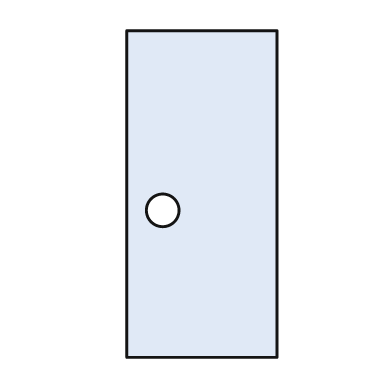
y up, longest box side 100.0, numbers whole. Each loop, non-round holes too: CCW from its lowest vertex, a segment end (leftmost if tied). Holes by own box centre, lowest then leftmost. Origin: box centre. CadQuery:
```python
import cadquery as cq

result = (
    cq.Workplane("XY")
    .moveTo(-23.0, -50.0)
    .lineTo(23.0, -50.0)
    .lineTo(23.0, 50.0)
    .lineTo(-23.0, 50.0)
    .close()
    .moveTo(-12.0, -5.0)
    .circle(5.0)
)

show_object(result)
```